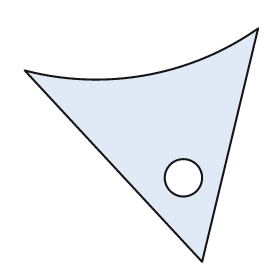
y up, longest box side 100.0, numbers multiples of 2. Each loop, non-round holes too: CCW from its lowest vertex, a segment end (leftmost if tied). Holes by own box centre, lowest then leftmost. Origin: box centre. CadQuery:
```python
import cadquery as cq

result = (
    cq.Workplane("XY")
    .moveTo(26.0, -50.0)
    .lineTo(50.0, 50.0)
    .threePointArc((2.0, 30.0), (-50.0, 32.0))
    .close()
    .moveTo(18.0, -14.0)
    .circle(8.0)
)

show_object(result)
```